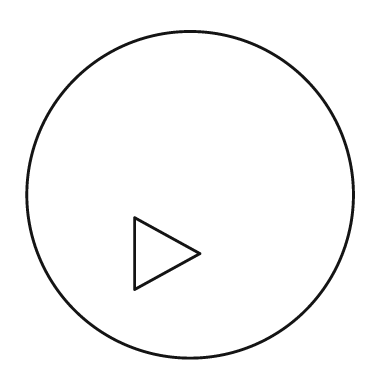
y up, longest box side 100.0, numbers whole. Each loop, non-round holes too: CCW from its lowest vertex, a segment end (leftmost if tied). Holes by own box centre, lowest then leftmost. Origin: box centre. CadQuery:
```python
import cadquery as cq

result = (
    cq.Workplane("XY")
    .moveTo(0.0, 0.0)
    .circle(50.0)
    .moveTo(-17.0, -29.0)
    .lineTo(3.0, -18.0)
    .lineTo(-17.0, -7.0)
    .close()
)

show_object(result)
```